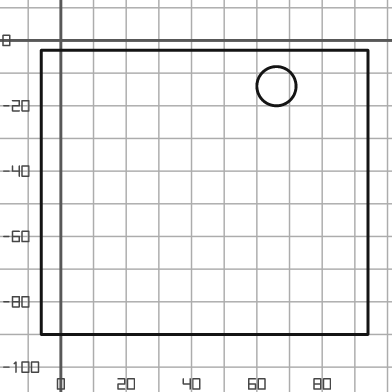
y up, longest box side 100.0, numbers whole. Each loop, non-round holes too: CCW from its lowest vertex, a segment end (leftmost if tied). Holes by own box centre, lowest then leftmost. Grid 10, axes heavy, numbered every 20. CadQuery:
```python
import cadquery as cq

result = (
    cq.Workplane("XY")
    .moveTo(-6.0, -90.0)
    .lineTo(94.0, -90.0)
    .lineTo(94.0, -3.0)
    .lineTo(-6.0, -3.0)
    .close()
    .moveTo(66.0, -14.0)
    .circle(6.0)
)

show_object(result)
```